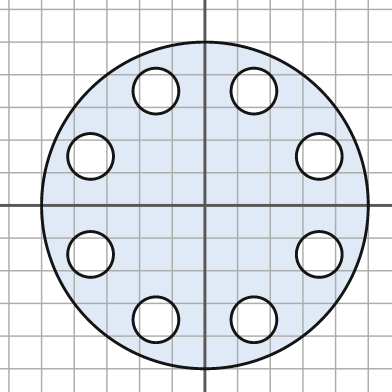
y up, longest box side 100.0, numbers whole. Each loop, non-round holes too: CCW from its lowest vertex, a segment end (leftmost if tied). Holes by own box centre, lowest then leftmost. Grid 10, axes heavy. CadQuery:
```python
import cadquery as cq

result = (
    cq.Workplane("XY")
    .moveTo(0.0, 0.0)
    .circle(50.0)
    .moveTo(-15.0, -35.0)
    .circle(7.0)
    .moveTo(15.0, -35.0)
    .circle(7.0)
    .moveTo(-35.0, -15.0)
    .circle(7.0)
    .moveTo(35.0, -15.0)
    .circle(7.0)
    .moveTo(-35.0, 15.0)
    .circle(7.0)
    .moveTo(35.0, 15.0)
    .circle(7.0)
    .moveTo(-15.0, 35.0)
    .circle(7.0)
    .moveTo(15.0, 35.0)
    .circle(7.0)
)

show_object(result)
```